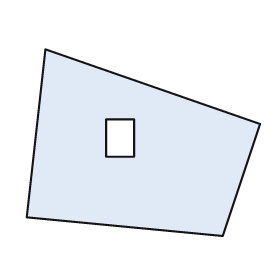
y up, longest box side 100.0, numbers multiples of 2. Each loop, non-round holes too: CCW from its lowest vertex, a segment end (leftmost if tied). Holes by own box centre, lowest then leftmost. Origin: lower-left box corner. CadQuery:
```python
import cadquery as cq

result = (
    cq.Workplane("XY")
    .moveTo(84.0, 0.0)
    .lineTo(100.0, 48.0)
    .lineTo(8.0, 80.0)
    .lineTo(0.0, 8.0)
    .close()
    .moveTo(34.0, 34.0)
    .lineTo(46.0, 34.0)
    .lineTo(46.0, 50.0)
    .lineTo(34.0, 50.0)
    .close()
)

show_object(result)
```